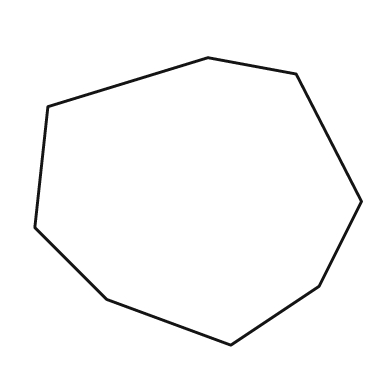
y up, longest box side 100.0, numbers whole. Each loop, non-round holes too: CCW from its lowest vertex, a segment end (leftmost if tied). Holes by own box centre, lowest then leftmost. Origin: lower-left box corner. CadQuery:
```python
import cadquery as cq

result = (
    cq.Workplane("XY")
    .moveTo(60.0, 0.0)
    .lineTo(87.0, 18.0)
    .lineTo(100.0, 44.0)
    .lineTo(80.0, 83.0)
    .lineTo(53.0, 88.0)
    .lineTo(4.0, 73.0)
    .lineTo(0.0, 36.0)
    .lineTo(22.0, 14.0)
    .close()
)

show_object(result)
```